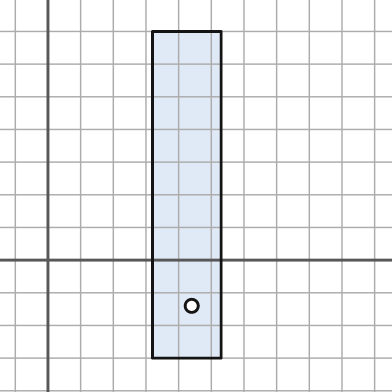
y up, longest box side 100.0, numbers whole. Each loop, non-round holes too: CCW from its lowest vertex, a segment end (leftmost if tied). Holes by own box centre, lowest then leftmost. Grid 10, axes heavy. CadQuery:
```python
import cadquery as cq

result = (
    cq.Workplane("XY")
    .moveTo(32.0, -30.0)
    .lineTo(53.0, -30.0)
    .lineTo(53.0, 70.0)
    .lineTo(32.0, 70.0)
    .close()
    .moveTo(44.0, -14.0)
    .circle(2.0)
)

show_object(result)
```